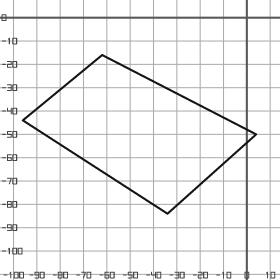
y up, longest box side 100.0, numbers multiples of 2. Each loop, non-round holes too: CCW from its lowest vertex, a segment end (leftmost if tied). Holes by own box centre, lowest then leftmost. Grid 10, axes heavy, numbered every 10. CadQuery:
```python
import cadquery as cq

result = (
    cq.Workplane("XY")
    .moveTo(-34.0, -84.0)
    .lineTo(4.0, -50.0)
    .lineTo(-62.0, -16.0)
    .lineTo(-96.0, -44.0)
    .close()
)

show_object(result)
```